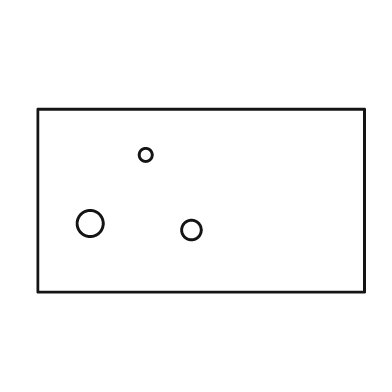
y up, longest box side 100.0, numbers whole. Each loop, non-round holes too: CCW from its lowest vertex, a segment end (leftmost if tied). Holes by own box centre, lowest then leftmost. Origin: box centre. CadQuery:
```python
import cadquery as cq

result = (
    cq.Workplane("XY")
    .moveTo(-50.0, -28.0)
    .lineTo(50.0, -28.0)
    .lineTo(50.0, 28.0)
    .lineTo(-50.0, 28.0)
    .close()
    .moveTo(-3.0, -9.0)
    .circle(3.0)
    .moveTo(-34.0, -7.0)
    .circle(4.0)
    .moveTo(-17.0, 14.0)
    .circle(2.0)
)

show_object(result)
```